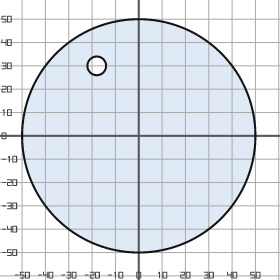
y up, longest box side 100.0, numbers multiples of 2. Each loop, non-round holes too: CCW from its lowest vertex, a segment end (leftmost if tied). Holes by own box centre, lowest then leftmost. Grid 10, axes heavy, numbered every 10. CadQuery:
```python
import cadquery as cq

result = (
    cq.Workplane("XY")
    .moveTo(0.0, 0.0)
    .circle(50.0)
    .moveTo(-18.0, 30.0)
    .circle(4.0)
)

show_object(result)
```